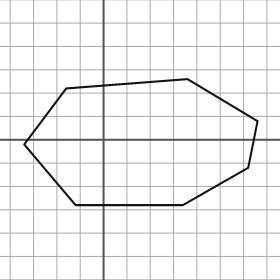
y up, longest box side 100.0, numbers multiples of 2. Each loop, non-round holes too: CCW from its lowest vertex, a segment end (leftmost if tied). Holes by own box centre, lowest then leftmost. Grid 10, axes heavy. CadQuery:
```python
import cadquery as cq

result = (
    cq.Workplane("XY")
    .moveTo(-12.0, -28.0)
    .lineTo(34.0, -28.0)
    .lineTo(62.0, -12.0)
    .lineTo(66.0, 8.0)
    .lineTo(36.0, 26.0)
    .lineTo(-16.0, 22.0)
    .lineTo(-34.0, -2.0)
    .close()
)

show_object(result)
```